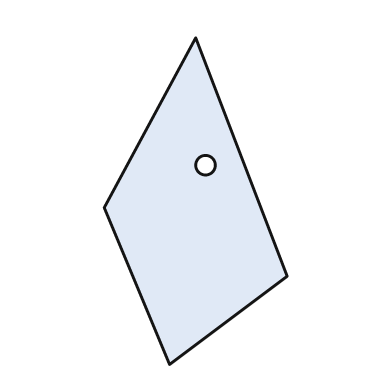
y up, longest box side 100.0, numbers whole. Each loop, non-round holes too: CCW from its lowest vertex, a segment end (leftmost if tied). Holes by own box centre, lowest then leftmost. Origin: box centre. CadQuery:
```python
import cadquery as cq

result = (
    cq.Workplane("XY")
    .moveTo(-8.0, -50.0)
    .lineTo(28.0, -23.0)
    .lineTo(0.0, 50.0)
    .lineTo(-28.0, -2.0)
    .close()
    .moveTo(3.0, 11.0)
    .circle(3.0)
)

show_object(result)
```